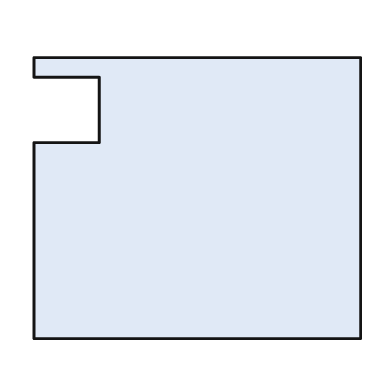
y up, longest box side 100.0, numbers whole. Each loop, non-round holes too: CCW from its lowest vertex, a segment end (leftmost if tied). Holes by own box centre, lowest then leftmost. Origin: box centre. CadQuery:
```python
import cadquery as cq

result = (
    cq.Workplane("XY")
    .moveTo(-50.0, -43.0)
    .lineTo(50.0, -43.0)
    .lineTo(50.0, 43.0)
    .lineTo(-50.0, 43.0)
    .lineTo(-50.0, 37.0)
    .lineTo(-30.0, 37.0)
    .lineTo(-30.0, 17.0)
    .lineTo(-50.0, 17.0)
    .close()
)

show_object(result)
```